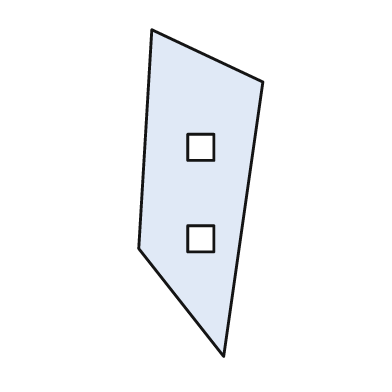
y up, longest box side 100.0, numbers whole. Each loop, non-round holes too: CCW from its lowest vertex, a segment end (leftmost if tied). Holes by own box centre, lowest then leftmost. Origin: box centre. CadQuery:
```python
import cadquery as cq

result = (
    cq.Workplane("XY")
    .moveTo(7.0, -50.0)
    .lineTo(19.0, 34.0)
    .lineTo(-15.0, 50.0)
    .lineTo(-19.0, -17.0)
    .close()
    .moveTo(-4.0, -18.0)
    .lineTo(4.0, -18.0)
    .lineTo(4.0, -10.0)
    .lineTo(-4.0, -10.0)
    .close()
    .moveTo(-4.0, 10.0)
    .lineTo(4.0, 10.0)
    .lineTo(4.0, 18.0)
    .lineTo(-4.0, 18.0)
    .close()
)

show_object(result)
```